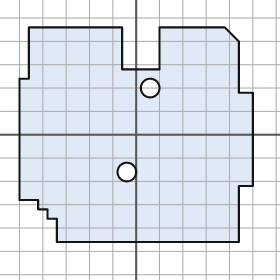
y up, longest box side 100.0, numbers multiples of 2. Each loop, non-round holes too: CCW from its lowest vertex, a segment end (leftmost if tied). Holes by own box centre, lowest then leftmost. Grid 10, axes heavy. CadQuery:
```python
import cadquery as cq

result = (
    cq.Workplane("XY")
    .moveTo(-34.0, -46.0)
    .lineTo(44.0, -46.0)
    .lineTo(44.0, -22.0)
    .lineTo(50.0, -22.0)
    .lineTo(50.0, 18.0)
    .lineTo(44.0, 18.0)
    .lineTo(44.0, 40.0)
    .lineTo(38.0, 46.0)
    .lineTo(10.0, 46.0)
    .lineTo(10.0, 28.0)
    .lineTo(-6.0, 28.0)
    .lineTo(-6.0, 46.0)
    .lineTo(-46.0, 46.0)
    .lineTo(-46.0, 24.0)
    .lineTo(-50.0, 24.0)
    .lineTo(-50.0, -28.0)
    .lineTo(-42.0, -28.0)
    .lineTo(-42.0, -32.0)
    .lineTo(-38.0, -32.0)
    .lineTo(-38.0, -36.0)
    .lineTo(-34.0, -36.0)
    .close()
    .moveTo(-4.0, -16.0)
    .circle(4.0)
    .moveTo(6.0, 20.0)
    .circle(4.0)
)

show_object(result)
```